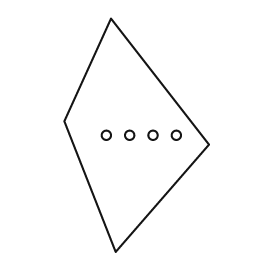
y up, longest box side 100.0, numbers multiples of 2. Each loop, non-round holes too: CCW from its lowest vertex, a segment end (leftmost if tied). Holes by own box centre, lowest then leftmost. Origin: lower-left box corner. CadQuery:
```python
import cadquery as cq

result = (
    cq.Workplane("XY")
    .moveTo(22.0, 0.0)
    .lineTo(62.0, 46.0)
    .lineTo(20.0, 100.0)
    .lineTo(0.0, 56.0)
    .close()
    .moveTo(18.0, 50.0)
    .circle(2.0)
    .moveTo(28.0, 50.0)
    .circle(2.0)
    .moveTo(38.0, 50.0)
    .circle(2.0)
    .moveTo(48.0, 50.0)
    .circle(2.0)
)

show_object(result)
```